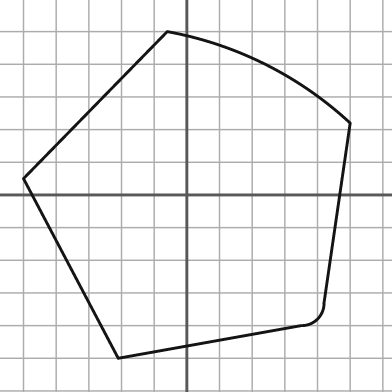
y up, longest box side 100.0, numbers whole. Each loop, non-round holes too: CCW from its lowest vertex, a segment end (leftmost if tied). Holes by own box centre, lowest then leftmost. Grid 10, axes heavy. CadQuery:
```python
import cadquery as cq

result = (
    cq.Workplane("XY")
    .moveTo(-21.0, -50.0)
    .lineTo(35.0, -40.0)
    .threePointArc((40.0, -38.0), (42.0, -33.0))
    .lineTo(50.0, 22.0)
    .threePointArc((24.0, 40.0), (-6.0, 50.0))
    .lineTo(-50.0, 5.0)
    .close()
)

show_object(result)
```